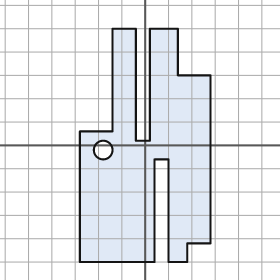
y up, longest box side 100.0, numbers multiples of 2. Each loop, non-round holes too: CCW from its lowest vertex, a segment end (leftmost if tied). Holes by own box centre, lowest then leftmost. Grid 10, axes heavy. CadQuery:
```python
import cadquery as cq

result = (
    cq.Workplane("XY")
    .moveTo(-28.0, -50.0)
    .lineTo(4.0, -50.0)
    .lineTo(4.0, -6.0)
    .lineTo(10.0, -6.0)
    .lineTo(10.0, -50.0)
    .lineTo(18.0, -50.0)
    .lineTo(18.0, -42.0)
    .lineTo(28.0, -42.0)
    .lineTo(28.0, 30.0)
    .lineTo(14.0, 30.0)
    .lineTo(14.0, 50.0)
    .lineTo(2.0, 50.0)
    .lineTo(2.0, 2.0)
    .lineTo(-4.0, 2.0)
    .lineTo(-4.0, 50.0)
    .lineTo(-14.0, 50.0)
    .lineTo(-14.0, 6.0)
    .lineTo(-28.0, 6.0)
    .close()
    .moveTo(-18.0, -2.0)
    .circle(4.0)
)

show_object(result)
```